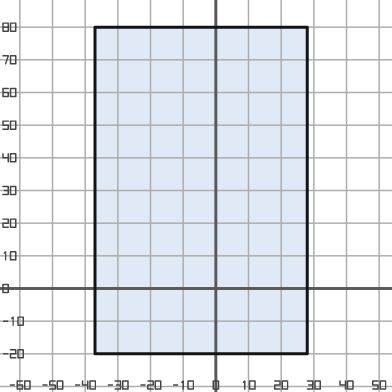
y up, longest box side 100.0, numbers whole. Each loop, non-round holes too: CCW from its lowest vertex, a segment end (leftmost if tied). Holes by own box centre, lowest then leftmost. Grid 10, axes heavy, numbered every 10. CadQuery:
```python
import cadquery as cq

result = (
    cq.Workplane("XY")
    .moveTo(-37.0, -20.0)
    .lineTo(28.0, -20.0)
    .lineTo(28.0, 80.0)
    .lineTo(-37.0, 80.0)
    .close()
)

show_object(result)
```